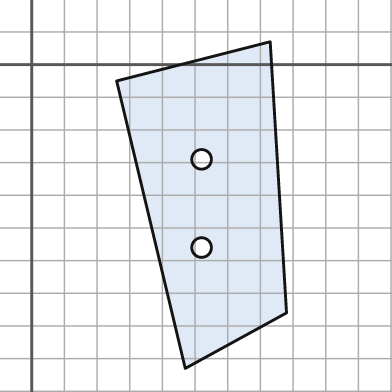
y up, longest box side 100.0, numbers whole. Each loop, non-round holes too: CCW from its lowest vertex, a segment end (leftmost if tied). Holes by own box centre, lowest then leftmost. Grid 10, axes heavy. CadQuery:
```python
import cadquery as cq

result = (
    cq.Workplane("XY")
    .moveTo(47.0, -93.0)
    .lineTo(78.0, -76.0)
    .lineTo(73.0, 7.0)
    .lineTo(26.0, -5.0)
    .close()
    .moveTo(52.0, -56.0)
    .circle(3.0)
    .moveTo(52.0, -29.0)
    .circle(3.0)
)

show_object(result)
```